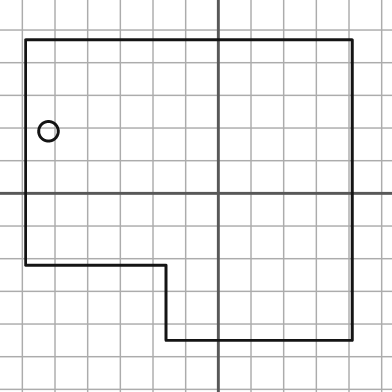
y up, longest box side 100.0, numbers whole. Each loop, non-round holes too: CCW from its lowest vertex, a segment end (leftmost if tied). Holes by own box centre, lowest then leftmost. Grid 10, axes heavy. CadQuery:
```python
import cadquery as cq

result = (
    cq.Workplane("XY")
    .moveTo(-16.0, -45.0)
    .lineTo(41.0, -45.0)
    .lineTo(41.0, 47.0)
    .lineTo(-59.0, 47.0)
    .lineTo(-59.0, -22.0)
    .lineTo(-16.0, -22.0)
    .close()
    .moveTo(-52.0, 19.0)
    .circle(3.0)
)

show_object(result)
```